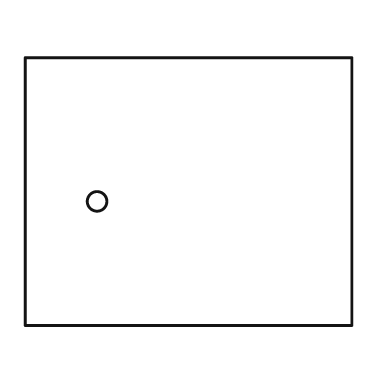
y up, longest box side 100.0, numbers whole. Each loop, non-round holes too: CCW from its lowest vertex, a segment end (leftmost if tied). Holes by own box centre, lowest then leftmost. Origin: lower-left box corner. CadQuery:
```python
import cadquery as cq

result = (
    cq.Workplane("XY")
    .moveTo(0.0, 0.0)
    .lineTo(100.0, 0.0)
    .lineTo(100.0, 82.0)
    .lineTo(0.0, 82.0)
    .close()
    .moveTo(22.0, 38.0)
    .circle(3.0)
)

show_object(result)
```